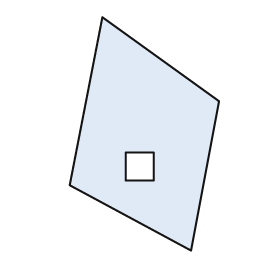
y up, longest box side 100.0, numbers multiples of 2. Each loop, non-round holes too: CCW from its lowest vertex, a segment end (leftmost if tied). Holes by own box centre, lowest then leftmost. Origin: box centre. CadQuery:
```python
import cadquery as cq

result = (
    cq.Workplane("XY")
    .moveTo(20.0, -50.0)
    .lineTo(32.0, 14.0)
    .lineTo(-18.0, 50.0)
    .lineTo(-32.0, -22.0)
    .close()
    .moveTo(-8.0, -20.0)
    .lineTo(4.0, -20.0)
    .lineTo(4.0, -8.0)
    .lineTo(-8.0, -8.0)
    .close()
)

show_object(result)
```